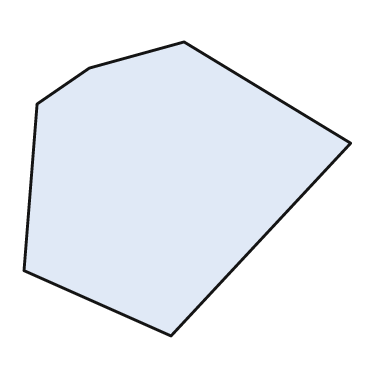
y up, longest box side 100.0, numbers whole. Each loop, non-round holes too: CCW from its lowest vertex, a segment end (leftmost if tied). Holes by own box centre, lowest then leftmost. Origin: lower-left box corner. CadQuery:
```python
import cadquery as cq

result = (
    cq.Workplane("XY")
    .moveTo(45.0, 0.0)
    .lineTo(100.0, 59.0)
    .lineTo(49.0, 90.0)
    .lineTo(20.0, 82.0)
    .lineTo(4.0, 71.0)
    .lineTo(0.0, 20.0)
    .close()
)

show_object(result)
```